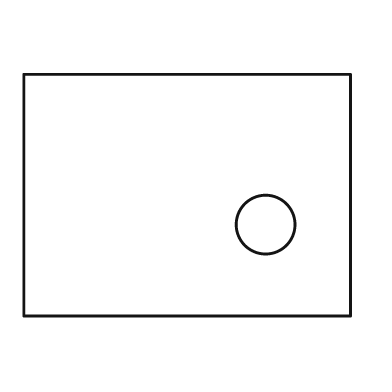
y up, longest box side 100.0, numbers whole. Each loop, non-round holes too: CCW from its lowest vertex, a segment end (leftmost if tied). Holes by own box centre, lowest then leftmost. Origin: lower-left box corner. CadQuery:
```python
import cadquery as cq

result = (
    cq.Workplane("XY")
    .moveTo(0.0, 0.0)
    .lineTo(100.0, 0.0)
    .lineTo(100.0, 74.0)
    .lineTo(0.0, 74.0)
    .close()
    .moveTo(74.0, 28.0)
    .circle(9.0)
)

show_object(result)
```